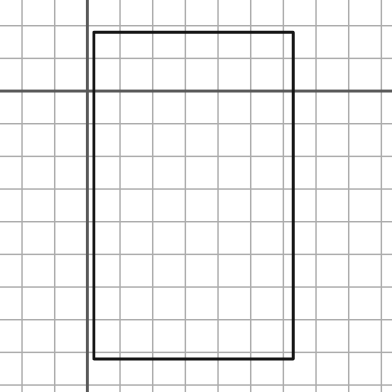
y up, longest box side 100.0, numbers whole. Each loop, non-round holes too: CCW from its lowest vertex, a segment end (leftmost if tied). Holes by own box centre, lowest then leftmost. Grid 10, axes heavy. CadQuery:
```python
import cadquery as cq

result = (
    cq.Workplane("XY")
    .moveTo(2.0, -82.0)
    .lineTo(63.0, -82.0)
    .lineTo(63.0, 18.0)
    .lineTo(2.0, 18.0)
    .close()
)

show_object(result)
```